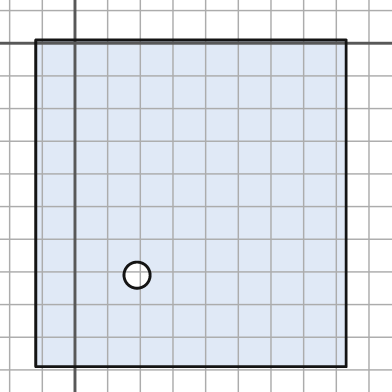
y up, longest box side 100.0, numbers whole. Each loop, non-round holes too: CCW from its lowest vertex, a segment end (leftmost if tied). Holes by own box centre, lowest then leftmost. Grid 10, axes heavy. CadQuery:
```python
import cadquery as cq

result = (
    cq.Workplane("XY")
    .moveTo(-12.0, -99.0)
    .lineTo(83.0, -99.0)
    .lineTo(83.0, 1.0)
    .lineTo(-12.0, 1.0)
    .close()
    .moveTo(19.0, -71.0)
    .circle(4.0)
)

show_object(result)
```